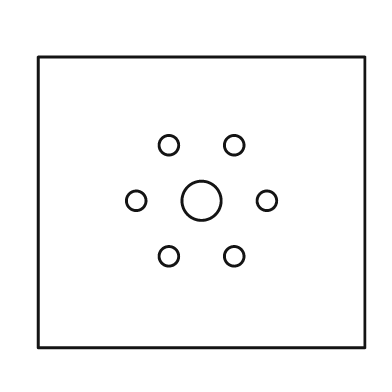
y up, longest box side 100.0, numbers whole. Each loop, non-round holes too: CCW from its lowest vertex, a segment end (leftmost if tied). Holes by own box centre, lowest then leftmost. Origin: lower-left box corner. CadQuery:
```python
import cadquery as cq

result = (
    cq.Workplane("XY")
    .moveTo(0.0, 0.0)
    .lineTo(100.0, 0.0)
    .lineTo(100.0, 89.0)
    .lineTo(0.0, 89.0)
    .close()
    .moveTo(40.0, 28.0)
    .circle(3.0)
    .moveTo(60.0, 28.0)
    .circle(3.0)
    .moveTo(30.0, 45.0)
    .circle(3.0)
    .moveTo(50.0, 45.0)
    .circle(6.0)
    .moveTo(70.0, 45.0)
    .circle(3.0)
    .moveTo(40.0, 62.0)
    .circle(3.0)
    .moveTo(60.0, 62.0)
    .circle(3.0)
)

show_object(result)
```